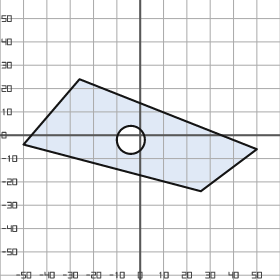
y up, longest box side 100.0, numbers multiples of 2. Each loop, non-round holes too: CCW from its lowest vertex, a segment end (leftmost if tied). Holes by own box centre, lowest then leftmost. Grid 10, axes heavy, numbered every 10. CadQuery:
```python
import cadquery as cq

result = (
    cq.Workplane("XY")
    .moveTo(26.0, -24.0)
    .lineTo(50.0, -6.0)
    .lineTo(-26.0, 24.0)
    .lineTo(-50.0, -4.0)
    .close()
    .moveTo(-4.0, -2.0)
    .circle(6.0)
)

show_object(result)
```